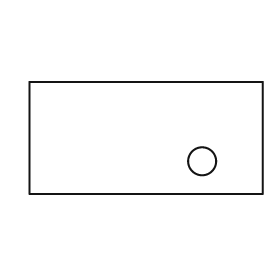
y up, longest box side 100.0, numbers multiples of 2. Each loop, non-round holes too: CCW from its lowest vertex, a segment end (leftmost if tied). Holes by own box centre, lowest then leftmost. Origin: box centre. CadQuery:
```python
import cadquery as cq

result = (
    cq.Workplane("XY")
    .moveTo(-50.0, -24.0)
    .lineTo(50.0, -24.0)
    .lineTo(50.0, 24.0)
    .lineTo(-50.0, 24.0)
    .close()
    .moveTo(24.0, -10.0)
    .circle(6.0)
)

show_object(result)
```